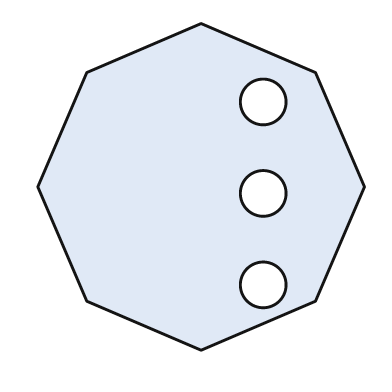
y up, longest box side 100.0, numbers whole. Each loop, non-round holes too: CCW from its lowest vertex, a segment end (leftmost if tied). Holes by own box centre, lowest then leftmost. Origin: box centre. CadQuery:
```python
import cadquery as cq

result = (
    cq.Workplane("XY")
    .moveTo(0.0, -50.0)
    .lineTo(35.0, -35.0)
    .lineTo(50.0, 0.0)
    .lineTo(35.0, 35.0)
    .lineTo(0.0, 50.0)
    .lineTo(-35.0, 35.0)
    .lineTo(-50.0, 0.0)
    .lineTo(-35.0, -35.0)
    .close()
    .moveTo(19.0, -30.0)
    .circle(7.0)
    .moveTo(19.0, -2.0)
    .circle(7.0)
    .moveTo(19.0, 26.0)
    .circle(7.0)
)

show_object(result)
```